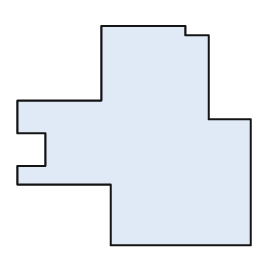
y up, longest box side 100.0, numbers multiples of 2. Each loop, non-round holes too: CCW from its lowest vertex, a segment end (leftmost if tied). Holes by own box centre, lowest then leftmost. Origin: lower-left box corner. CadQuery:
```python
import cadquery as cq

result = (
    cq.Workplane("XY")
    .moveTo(40.0, 0.0)
    .lineTo(100.0, 0.0)
    .lineTo(100.0, 54.0)
    .lineTo(82.0, 54.0)
    .lineTo(82.0, 90.0)
    .lineTo(72.0, 90.0)
    .lineTo(72.0, 94.0)
    .lineTo(36.0, 94.0)
    .lineTo(36.0, 62.0)
    .lineTo(0.0, 62.0)
    .lineTo(0.0, 48.0)
    .lineTo(12.0, 48.0)
    .lineTo(12.0, 34.0)
    .lineTo(0.0, 34.0)
    .lineTo(0.0, 26.0)
    .lineTo(40.0, 26.0)
    .close()
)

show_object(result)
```